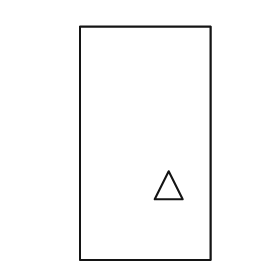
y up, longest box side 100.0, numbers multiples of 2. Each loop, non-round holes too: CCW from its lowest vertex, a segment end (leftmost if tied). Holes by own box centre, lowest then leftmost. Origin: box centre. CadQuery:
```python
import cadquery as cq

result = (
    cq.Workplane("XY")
    .moveTo(-28.0, -50.0)
    .lineTo(28.0, -50.0)
    .lineTo(28.0, 50.0)
    .lineTo(-28.0, 50.0)
    .close()
    .moveTo(4.0, -24.0)
    .lineTo(16.0, -24.0)
    .lineTo(10.0, -12.0)
    .close()
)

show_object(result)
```